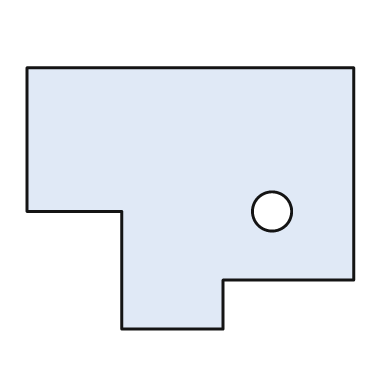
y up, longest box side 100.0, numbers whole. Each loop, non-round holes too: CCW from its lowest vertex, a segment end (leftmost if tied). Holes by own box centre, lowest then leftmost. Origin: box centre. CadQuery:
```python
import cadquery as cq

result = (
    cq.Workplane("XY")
    .moveTo(-21.0, -40.0)
    .lineTo(10.0, -40.0)
    .lineTo(10.0, -25.0)
    .lineTo(50.0, -25.0)
    .lineTo(50.0, 40.0)
    .lineTo(-50.0, 40.0)
    .lineTo(-50.0, -4.0)
    .lineTo(-21.0, -4.0)
    .close()
    .moveTo(25.0, -4.0)
    .circle(6.0)
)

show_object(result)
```